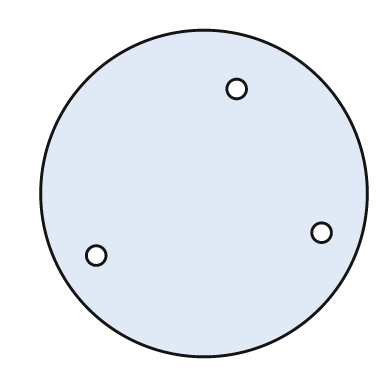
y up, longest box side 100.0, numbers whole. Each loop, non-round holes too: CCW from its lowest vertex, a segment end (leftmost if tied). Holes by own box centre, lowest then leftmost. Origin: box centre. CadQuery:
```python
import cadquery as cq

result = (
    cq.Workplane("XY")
    .moveTo(0.0, 0.0)
    .circle(50.0)
    .moveTo(-33.0, -19.0)
    .circle(3.0)
    .moveTo(36.0, -12.0)
    .circle(3.0)
    .moveTo(10.0, 32.0)
    .circle(3.0)
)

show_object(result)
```